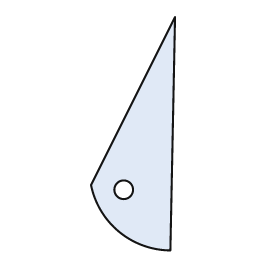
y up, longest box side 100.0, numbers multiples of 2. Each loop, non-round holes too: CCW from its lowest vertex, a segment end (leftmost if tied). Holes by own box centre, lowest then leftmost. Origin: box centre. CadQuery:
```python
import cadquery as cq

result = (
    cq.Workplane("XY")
    .moveTo(16.0, -50.0)
    .lineTo(18.0, 50.0)
    .lineTo(-18.0, -22.0)
    .threePointArc((-6.0, -42.0), (16.0, -50.0))
    .close()
    .moveTo(-4.0, -24.0)
    .circle(4.0)
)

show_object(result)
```